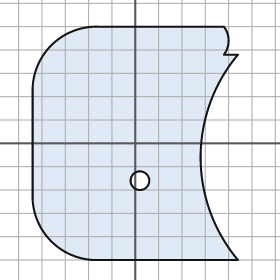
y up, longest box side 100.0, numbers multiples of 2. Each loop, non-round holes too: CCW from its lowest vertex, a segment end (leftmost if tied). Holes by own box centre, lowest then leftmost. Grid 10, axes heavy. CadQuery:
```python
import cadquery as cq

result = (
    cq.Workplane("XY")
    .moveTo(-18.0, -50.0)
    .lineTo(44.0, -50.0)
    .threePointArc((28.0, -6.0), (44.0, 38.0))
    .lineTo(38.0, 38.0)
    .threePointArc((40.0, 44.0), (38.0, 50.0))
    .lineTo(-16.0, 50.0)
    .threePointArc((-36.0, 42.0), (-44.0, 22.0))
    .lineTo(-44.0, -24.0)
    .threePointArc((-36.0, -42.0), (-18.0, -50.0))
    .close()
    .moveTo(2.0, -16.0)
    .circle(4.0)
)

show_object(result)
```